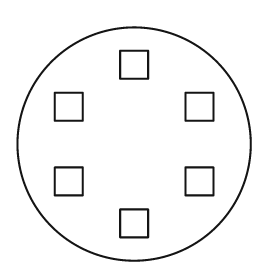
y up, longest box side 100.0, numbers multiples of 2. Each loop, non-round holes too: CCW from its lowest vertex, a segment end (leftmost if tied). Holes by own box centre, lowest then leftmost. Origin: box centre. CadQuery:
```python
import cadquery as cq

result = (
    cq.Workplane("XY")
    .moveTo(0.0, 0.0)
    .circle(50.0)
    .moveTo(-6.0, -40.0)
    .lineTo(6.0, -40.0)
    .lineTo(6.0, -28.0)
    .lineTo(-6.0, -28.0)
    .close()
    .moveTo(-34.0, -22.0)
    .lineTo(-22.0, -22.0)
    .lineTo(-22.0, -10.0)
    .lineTo(-34.0, -10.0)
    .close()
    .moveTo(22.0, -22.0)
    .lineTo(34.0, -22.0)
    .lineTo(34.0, -10.0)
    .lineTo(22.0, -10.0)
    .close()
    .moveTo(-34.0, 10.0)
    .lineTo(-22.0, 10.0)
    .lineTo(-22.0, 22.0)
    .lineTo(-34.0, 22.0)
    .close()
    .moveTo(22.0, 10.0)
    .lineTo(34.0, 10.0)
    .lineTo(34.0, 22.0)
    .lineTo(22.0, 22.0)
    .close()
    .moveTo(-6.0, 28.0)
    .lineTo(6.0, 28.0)
    .lineTo(6.0, 40.0)
    .lineTo(-6.0, 40.0)
    .close()
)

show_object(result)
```